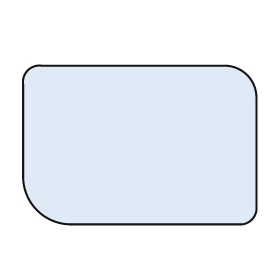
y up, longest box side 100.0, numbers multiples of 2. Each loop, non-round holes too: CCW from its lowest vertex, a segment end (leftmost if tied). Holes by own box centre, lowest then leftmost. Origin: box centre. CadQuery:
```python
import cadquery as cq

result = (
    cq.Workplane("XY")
    .moveTo(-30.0, -34.0)
    .lineTo(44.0, -34.0)
    .threePointArc((48.0, -32.0), (50.0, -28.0))
    .lineTo(50.0, 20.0)
    .threePointArc((46.0, 30.0), (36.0, 34.0))
    .lineTo(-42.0, 34.0)
    .threePointArc((-48.0, 32.0), (-50.0, 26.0))
    .lineTo(-50.0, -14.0)
    .threePointArc((-44.0, -28.0), (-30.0, -34.0))
    .close()
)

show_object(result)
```